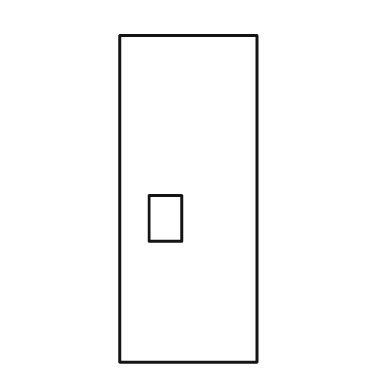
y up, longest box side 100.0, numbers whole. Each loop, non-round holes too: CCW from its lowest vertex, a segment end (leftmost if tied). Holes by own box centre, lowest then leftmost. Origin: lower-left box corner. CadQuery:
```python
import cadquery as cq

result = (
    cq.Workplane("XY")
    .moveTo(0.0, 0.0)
    .lineTo(42.0, 0.0)
    .lineTo(42.0, 100.0)
    .lineTo(0.0, 100.0)
    .close()
    .moveTo(9.0, 37.0)
    .lineTo(19.0, 37.0)
    .lineTo(19.0, 51.0)
    .lineTo(9.0, 51.0)
    .close()
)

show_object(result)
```